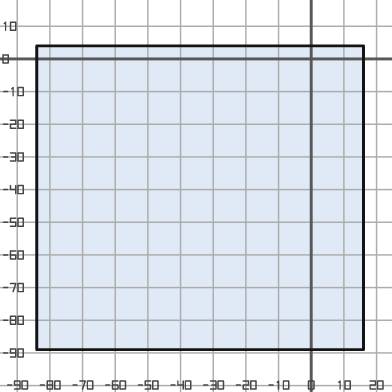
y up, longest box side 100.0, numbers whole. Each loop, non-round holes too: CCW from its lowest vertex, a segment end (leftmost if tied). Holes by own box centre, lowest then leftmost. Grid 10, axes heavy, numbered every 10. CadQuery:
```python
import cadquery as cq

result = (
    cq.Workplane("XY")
    .moveTo(-84.0, -89.0)
    .lineTo(16.0, -89.0)
    .lineTo(16.0, 4.0)
    .lineTo(-84.0, 4.0)
    .close()
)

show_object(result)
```